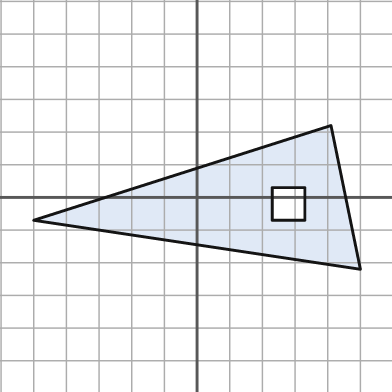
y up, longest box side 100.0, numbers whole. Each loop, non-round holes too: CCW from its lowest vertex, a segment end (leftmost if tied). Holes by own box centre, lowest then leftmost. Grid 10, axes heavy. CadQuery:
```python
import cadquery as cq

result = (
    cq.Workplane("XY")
    .moveTo(50.0, -22.0)
    .lineTo(41.0, 22.0)
    .lineTo(-50.0, -7.0)
    .close()
    .moveTo(23.0, -7.0)
    .lineTo(33.0, -7.0)
    .lineTo(33.0, 3.0)
    .lineTo(23.0, 3.0)
    .close()
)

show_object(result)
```